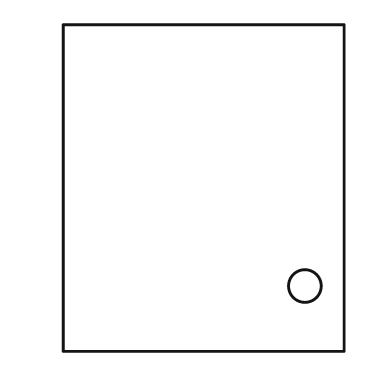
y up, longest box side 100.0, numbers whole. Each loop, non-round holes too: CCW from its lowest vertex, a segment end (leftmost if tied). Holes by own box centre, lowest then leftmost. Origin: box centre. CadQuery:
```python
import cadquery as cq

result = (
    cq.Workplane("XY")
    .moveTo(-43.0, -50.0)
    .lineTo(43.0, -50.0)
    .lineTo(43.0, 50.0)
    .lineTo(-43.0, 50.0)
    .close()
    .moveTo(31.0, -30.0)
    .circle(5.0)
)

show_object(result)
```